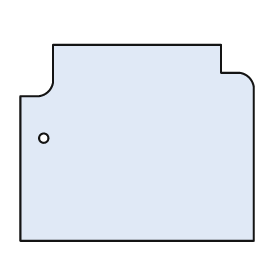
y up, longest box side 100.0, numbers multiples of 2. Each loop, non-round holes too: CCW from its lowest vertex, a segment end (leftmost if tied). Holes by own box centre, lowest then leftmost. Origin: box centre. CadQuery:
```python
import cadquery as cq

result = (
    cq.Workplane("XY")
    .moveTo(-50.0, -42.0)
    .lineTo(50.0, -42.0)
    .lineTo(50.0, 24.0)
    .threePointArc((48.0, 28.0), (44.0, 30.0))
    .lineTo(36.0, 30.0)
    .lineTo(36.0, 42.0)
    .lineTo(-36.0, 42.0)
    .lineTo(-36.0, 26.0)
    .threePointArc((-38.0, 22.0), (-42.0, 20.0))
    .lineTo(-50.0, 20.0)
    .close()
    .moveTo(-40.0, 2.0)
    .circle(2.0)
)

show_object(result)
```